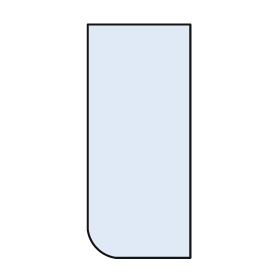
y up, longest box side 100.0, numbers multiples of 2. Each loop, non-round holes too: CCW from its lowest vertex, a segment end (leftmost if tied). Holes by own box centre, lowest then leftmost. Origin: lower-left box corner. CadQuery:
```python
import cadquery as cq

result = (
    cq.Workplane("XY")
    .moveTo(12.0, 0.0)
    .lineTo(44.0, 0.0)
    .lineTo(44.0, 100.0)
    .lineTo(0.0, 100.0)
    .lineTo(0.0, 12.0)
    .threePointArc((4.0, 4.0), (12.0, 0.0))
    .close()
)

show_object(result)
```